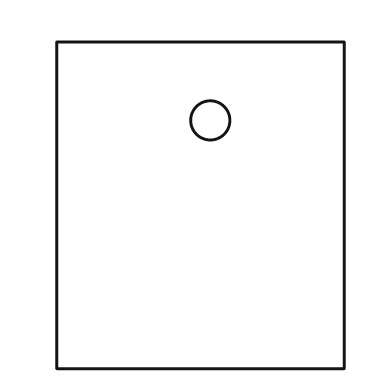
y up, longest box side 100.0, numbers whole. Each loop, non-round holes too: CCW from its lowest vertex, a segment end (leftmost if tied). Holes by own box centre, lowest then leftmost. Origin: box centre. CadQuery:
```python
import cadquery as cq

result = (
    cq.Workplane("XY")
    .moveTo(-44.0, -50.0)
    .lineTo(44.0, -50.0)
    .lineTo(44.0, 50.0)
    .lineTo(-44.0, 50.0)
    .close()
    .moveTo(3.0, 26.0)
    .circle(6.0)
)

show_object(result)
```